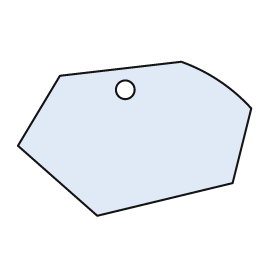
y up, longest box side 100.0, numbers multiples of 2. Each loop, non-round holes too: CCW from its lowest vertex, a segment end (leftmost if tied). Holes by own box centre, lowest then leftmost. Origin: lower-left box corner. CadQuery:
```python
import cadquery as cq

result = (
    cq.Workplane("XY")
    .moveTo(34.0, 0.0)
    .lineTo(92.0, 14.0)
    .lineTo(100.0, 46.0)
    .threePointArc((86.0, 58.0), (70.0, 66.0))
    .lineTo(18.0, 60.0)
    .lineTo(0.0, 30.0)
    .close()
    .moveTo(46.0, 54.0)
    .circle(4.0)
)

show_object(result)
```